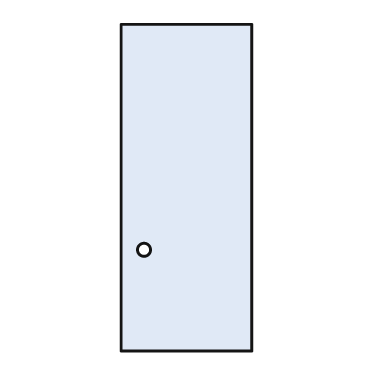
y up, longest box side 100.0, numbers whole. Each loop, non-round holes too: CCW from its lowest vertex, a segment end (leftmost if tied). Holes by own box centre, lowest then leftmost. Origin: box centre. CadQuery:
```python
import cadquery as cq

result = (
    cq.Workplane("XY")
    .moveTo(-20.0, -50.0)
    .lineTo(20.0, -50.0)
    .lineTo(20.0, 50.0)
    .lineTo(-20.0, 50.0)
    .close()
    .moveTo(-13.0, -19.0)
    .circle(2.0)
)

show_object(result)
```